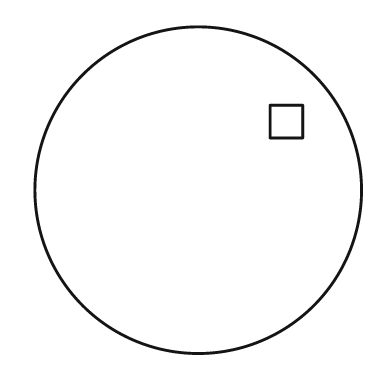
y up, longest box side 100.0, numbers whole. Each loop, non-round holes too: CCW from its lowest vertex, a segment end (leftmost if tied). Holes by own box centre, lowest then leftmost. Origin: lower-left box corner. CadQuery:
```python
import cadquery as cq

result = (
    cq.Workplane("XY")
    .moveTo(50.0, 50.0)
    .circle(50.0)
    .moveTo(72.0, 66.0)
    .lineTo(82.0, 66.0)
    .lineTo(82.0, 76.0)
    .lineTo(72.0, 76.0)
    .close()
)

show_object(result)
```